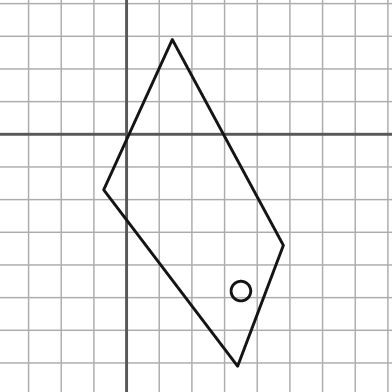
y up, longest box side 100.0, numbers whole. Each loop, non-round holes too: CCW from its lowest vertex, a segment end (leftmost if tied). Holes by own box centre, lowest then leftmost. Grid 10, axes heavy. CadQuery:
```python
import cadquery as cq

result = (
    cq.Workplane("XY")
    .moveTo(34.0, -71.0)
    .lineTo(48.0, -34.0)
    .lineTo(14.0, 29.0)
    .lineTo(-7.0, -17.0)
    .close()
    .moveTo(35.0, -48.0)
    .circle(3.0)
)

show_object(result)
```